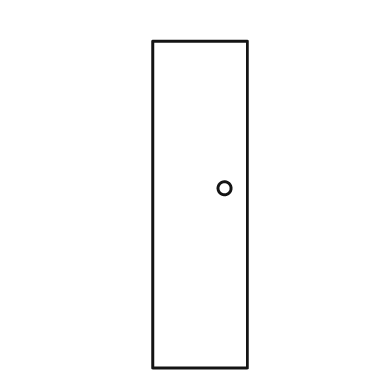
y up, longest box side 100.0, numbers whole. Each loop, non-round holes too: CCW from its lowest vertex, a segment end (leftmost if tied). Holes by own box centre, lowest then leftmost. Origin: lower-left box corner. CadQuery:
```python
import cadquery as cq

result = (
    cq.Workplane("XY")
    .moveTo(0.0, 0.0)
    .lineTo(29.0, 0.0)
    .lineTo(29.0, 100.0)
    .lineTo(0.0, 100.0)
    .close()
    .moveTo(22.0, 55.0)
    .circle(2.0)
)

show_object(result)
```